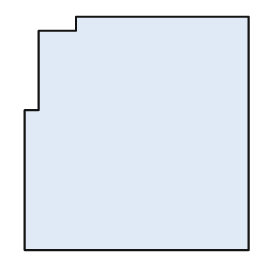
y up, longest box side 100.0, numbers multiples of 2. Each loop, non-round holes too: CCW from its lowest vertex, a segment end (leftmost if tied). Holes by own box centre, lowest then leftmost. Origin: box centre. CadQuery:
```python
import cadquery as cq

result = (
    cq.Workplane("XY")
    .moveTo(-48.0, -50.0)
    .lineTo(48.0, -50.0)
    .lineTo(48.0, 50.0)
    .lineTo(-26.0, 50.0)
    .lineTo(-26.0, 44.0)
    .lineTo(-42.0, 44.0)
    .lineTo(-42.0, 10.0)
    .lineTo(-48.0, 10.0)
    .close()
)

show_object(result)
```